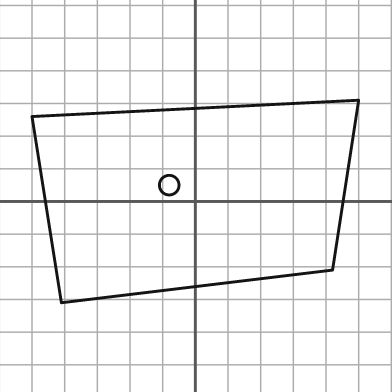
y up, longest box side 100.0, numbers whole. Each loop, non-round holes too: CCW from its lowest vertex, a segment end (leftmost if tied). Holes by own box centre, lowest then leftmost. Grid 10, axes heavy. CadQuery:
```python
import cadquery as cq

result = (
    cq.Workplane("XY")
    .moveTo(-41.0, -31.0)
    .lineTo(42.0, -21.0)
    .lineTo(50.0, 31.0)
    .lineTo(-50.0, 26.0)
    .close()
    .moveTo(-8.0, 5.0)
    .circle(3.0)
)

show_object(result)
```